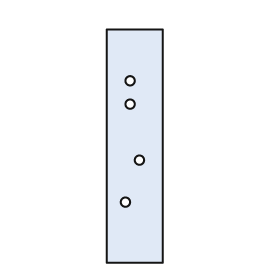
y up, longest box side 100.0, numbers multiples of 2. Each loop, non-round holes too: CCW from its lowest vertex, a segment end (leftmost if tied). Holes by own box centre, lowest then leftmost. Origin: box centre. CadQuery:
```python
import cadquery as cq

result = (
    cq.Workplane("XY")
    .moveTo(-12.0, -50.0)
    .lineTo(12.0, -50.0)
    .lineTo(12.0, 50.0)
    .lineTo(-12.0, 50.0)
    .close()
    .moveTo(-4.0, -24.0)
    .circle(2.0)
    .moveTo(2.0, -6.0)
    .circle(2.0)
    .moveTo(-2.0, 18.0)
    .circle(2.0)
    .moveTo(-2.0, 28.0)
    .circle(2.0)
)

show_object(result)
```